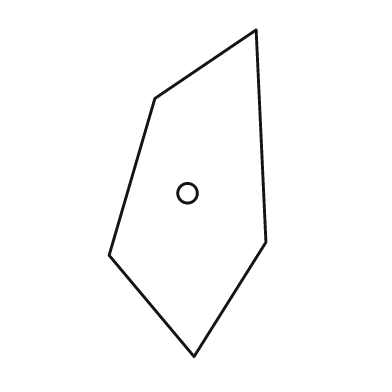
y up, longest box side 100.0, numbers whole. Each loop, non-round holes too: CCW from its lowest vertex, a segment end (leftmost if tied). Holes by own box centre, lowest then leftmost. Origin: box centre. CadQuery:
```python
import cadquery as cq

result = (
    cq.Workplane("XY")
    .moveTo(2.0, -50.0)
    .lineTo(24.0, -15.0)
    .lineTo(21.0, 50.0)
    .lineTo(-10.0, 29.0)
    .lineTo(-24.0, -19.0)
    .close()
    .moveTo(0.0, 0.0)
    .circle(3.0)
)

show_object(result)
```